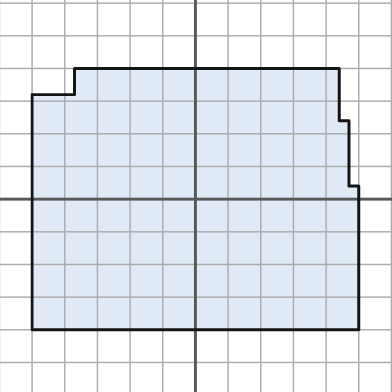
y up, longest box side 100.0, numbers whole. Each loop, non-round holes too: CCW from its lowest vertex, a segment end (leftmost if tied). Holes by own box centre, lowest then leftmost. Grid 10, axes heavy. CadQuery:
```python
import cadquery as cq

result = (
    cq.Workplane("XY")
    .moveTo(-50.0, -40.0)
    .lineTo(50.0, -40.0)
    .lineTo(50.0, 4.0)
    .lineTo(47.0, 4.0)
    .lineTo(47.0, 24.0)
    .lineTo(44.0, 24.0)
    .lineTo(44.0, 40.0)
    .lineTo(-37.0, 40.0)
    .lineTo(-37.0, 32.0)
    .lineTo(-50.0, 32.0)
    .close()
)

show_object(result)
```